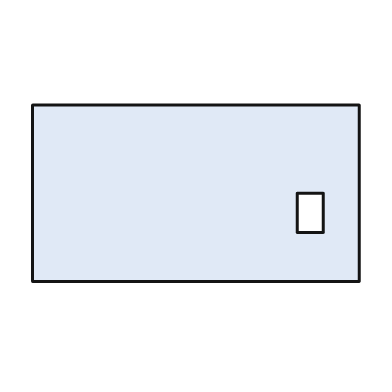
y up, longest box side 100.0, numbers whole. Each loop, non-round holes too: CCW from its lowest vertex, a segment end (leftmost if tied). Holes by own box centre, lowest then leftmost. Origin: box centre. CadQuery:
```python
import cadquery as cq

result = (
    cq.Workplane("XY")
    .moveTo(-50.0, -27.0)
    .lineTo(50.0, -27.0)
    .lineTo(50.0, 27.0)
    .lineTo(-50.0, 27.0)
    .close()
    .moveTo(31.0, -12.0)
    .lineTo(39.0, -12.0)
    .lineTo(39.0, 0.0)
    .lineTo(31.0, 0.0)
    .close()
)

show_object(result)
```